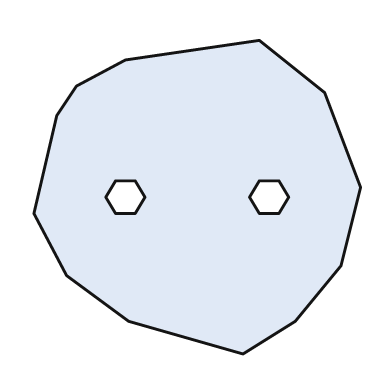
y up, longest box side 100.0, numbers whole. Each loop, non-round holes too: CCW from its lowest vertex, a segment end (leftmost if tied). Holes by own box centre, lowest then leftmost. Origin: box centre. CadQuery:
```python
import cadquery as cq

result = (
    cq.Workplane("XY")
    .moveTo(14.0, -48.0)
    .lineTo(30.0, -38.0)
    .lineTo(44.0, -21.0)
    .lineTo(50.0, 3.0)
    .lineTo(39.0, 32.0)
    .lineTo(19.0, 48.0)
    .lineTo(-22.0, 42.0)
    .lineTo(-37.0, 34.0)
    .lineTo(-43.0, 25.0)
    .lineTo(-50.0, -5.0)
    .lineTo(-40.0, -24.0)
    .lineTo(-21.0, -38.0)
    .close()
    .moveTo(-25.0, -5.0)
    .lineTo(-19.0, -5.0)
    .lineTo(-16.0, 0.0)
    .lineTo(-19.0, 5.0)
    .lineTo(-25.0, 5.0)
    .lineTo(-28.0, 0.0)
    .close()
    .moveTo(19.0, -5.0)
    .lineTo(25.0, -5.0)
    .lineTo(28.0, 0.0)
    .lineTo(25.0, 5.0)
    .lineTo(19.0, 5.0)
    .lineTo(16.0, 0.0)
    .close()
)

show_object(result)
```